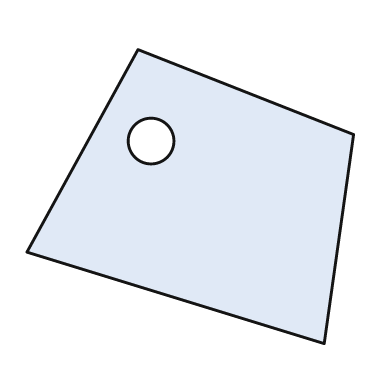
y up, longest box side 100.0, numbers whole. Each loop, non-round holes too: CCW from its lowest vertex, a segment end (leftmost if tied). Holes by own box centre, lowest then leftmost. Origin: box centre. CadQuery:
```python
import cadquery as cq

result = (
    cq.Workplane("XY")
    .moveTo(41.0, -45.0)
    .lineTo(50.0, 19.0)
    .lineTo(-16.0, 45.0)
    .lineTo(-50.0, -17.0)
    .close()
    .moveTo(-12.0, 17.0)
    .circle(7.0)
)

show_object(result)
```